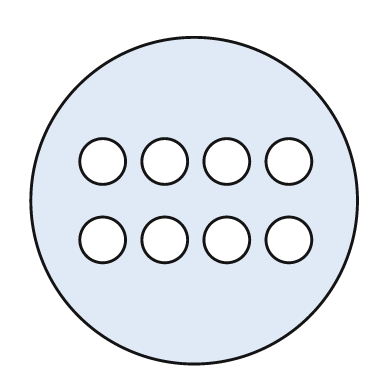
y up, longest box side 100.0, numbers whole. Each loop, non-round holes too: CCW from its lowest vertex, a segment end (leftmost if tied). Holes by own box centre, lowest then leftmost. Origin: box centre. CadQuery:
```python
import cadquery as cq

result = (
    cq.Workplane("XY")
    .moveTo(0.0, 0.0)
    .circle(50.0)
    .moveTo(-28.0, -12.0)
    .circle(7.0)
    .moveTo(-9.0, -12.0)
    .circle(7.0)
    .moveTo(10.0, -12.0)
    .circle(7.0)
    .moveTo(29.0, -12.0)
    .circle(7.0)
    .moveTo(-28.0, 12.0)
    .circle(7.0)
    .moveTo(-9.0, 12.0)
    .circle(7.0)
    .moveTo(10.0, 12.0)
    .circle(7.0)
    .moveTo(29.0, 12.0)
    .circle(7.0)
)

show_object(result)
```